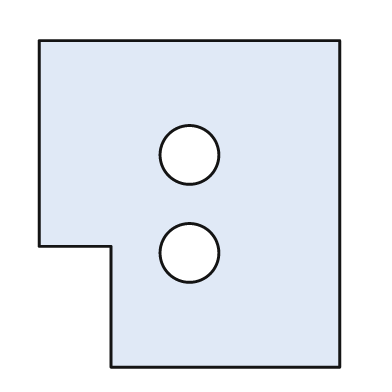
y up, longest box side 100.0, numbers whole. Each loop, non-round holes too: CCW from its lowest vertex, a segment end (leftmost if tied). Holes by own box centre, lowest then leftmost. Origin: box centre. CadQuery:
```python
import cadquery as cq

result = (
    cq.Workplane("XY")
    .moveTo(-24.0, -50.0)
    .lineTo(46.0, -50.0)
    .lineTo(46.0, 50.0)
    .lineTo(-46.0, 50.0)
    .lineTo(-46.0, -13.0)
    .lineTo(-24.0, -13.0)
    .close()
    .moveTo(0.0, -15.0)
    .circle(9.0)
    .moveTo(0.0, 15.0)
    .circle(9.0)
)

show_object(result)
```